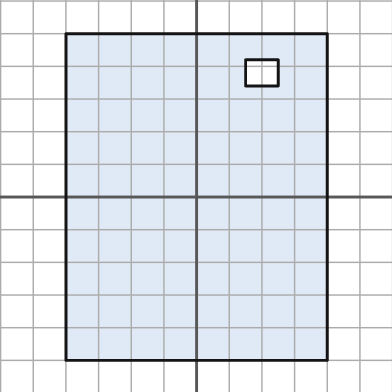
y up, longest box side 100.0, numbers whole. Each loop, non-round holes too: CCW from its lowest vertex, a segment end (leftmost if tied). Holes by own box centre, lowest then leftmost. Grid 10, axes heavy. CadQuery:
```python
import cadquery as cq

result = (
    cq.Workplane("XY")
    .moveTo(-40.0, -50.0)
    .lineTo(40.0, -50.0)
    .lineTo(40.0, 50.0)
    .lineTo(-40.0, 50.0)
    .close()
    .moveTo(15.0, 34.0)
    .lineTo(25.0, 34.0)
    .lineTo(25.0, 42.0)
    .lineTo(15.0, 42.0)
    .close()
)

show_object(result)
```